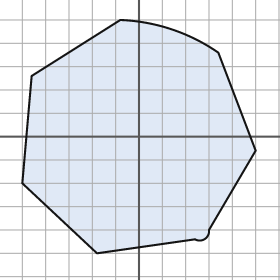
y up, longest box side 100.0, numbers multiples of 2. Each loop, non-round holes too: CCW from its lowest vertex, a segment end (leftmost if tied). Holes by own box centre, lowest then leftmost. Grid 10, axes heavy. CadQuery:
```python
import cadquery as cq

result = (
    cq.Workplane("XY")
    .moveTo(-18.0, -50.0)
    .lineTo(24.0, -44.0)
    .threePointArc((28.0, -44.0), (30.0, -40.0))
    .lineTo(50.0, -6.0)
    .lineTo(34.0, 36.0)
    .threePointArc((14.0, 46.0), (-8.0, 50.0))
    .lineTo(-46.0, 26.0)
    .lineTo(-50.0, -20.0)
    .close()
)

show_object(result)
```